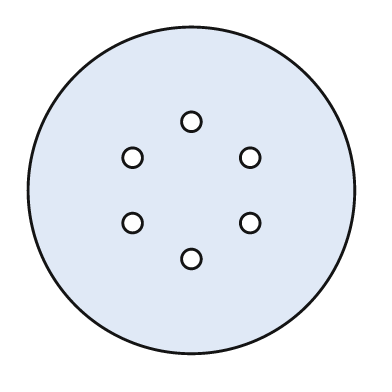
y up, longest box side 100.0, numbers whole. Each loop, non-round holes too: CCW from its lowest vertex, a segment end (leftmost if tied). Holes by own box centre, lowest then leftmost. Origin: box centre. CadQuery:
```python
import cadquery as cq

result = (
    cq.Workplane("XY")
    .moveTo(0.0, 0.0)
    .circle(50.0)
    .moveTo(0.0, -21.0)
    .circle(3.0)
    .moveTo(-18.0, -10.0)
    .circle(3.0)
    .moveTo(18.0, -10.0)
    .circle(3.0)
    .moveTo(-18.0, 10.0)
    .circle(3.0)
    .moveTo(18.0, 10.0)
    .circle(3.0)
    .moveTo(0.0, 21.0)
    .circle(3.0)
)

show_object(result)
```